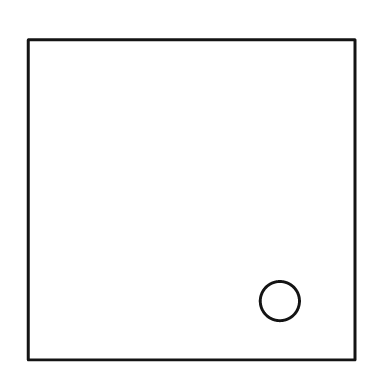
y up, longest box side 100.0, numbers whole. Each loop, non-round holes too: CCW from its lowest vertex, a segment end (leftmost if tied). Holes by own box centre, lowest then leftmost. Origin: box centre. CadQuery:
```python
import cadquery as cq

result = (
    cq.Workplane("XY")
    .moveTo(-50.0, -49.0)
    .lineTo(50.0, -49.0)
    .lineTo(50.0, 49.0)
    .lineTo(-50.0, 49.0)
    .close()
    .moveTo(27.0, -31.0)
    .circle(6.0)
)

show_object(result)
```